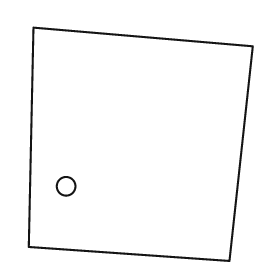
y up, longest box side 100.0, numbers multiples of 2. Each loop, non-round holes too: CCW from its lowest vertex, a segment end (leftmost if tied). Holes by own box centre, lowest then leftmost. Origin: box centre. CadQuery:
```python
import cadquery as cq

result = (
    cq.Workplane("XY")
    .moveTo(38.0, -50.0)
    .lineTo(48.0, 42.0)
    .lineTo(-46.0, 50.0)
    .lineTo(-48.0, -44.0)
    .close()
    .moveTo(-32.0, -18.0)
    .circle(4.0)
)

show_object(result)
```